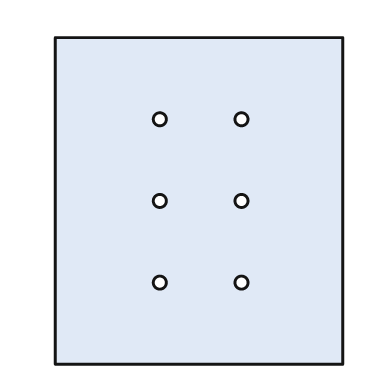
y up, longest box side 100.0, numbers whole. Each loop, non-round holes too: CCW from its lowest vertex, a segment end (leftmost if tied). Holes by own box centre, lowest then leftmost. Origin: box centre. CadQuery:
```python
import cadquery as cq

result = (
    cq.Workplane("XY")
    .moveTo(-44.0, -50.0)
    .lineTo(44.0, -50.0)
    .lineTo(44.0, 50.0)
    .lineTo(-44.0, 50.0)
    .close()
    .moveTo(-12.0, -25.0)
    .circle(2.0)
    .moveTo(13.0, -25.0)
    .circle(2.0)
    .moveTo(-12.0, 0.0)
    .circle(2.0)
    .moveTo(13.0, 0.0)
    .circle(2.0)
    .moveTo(-12.0, 25.0)
    .circle(2.0)
    .moveTo(13.0, 25.0)
    .circle(2.0)
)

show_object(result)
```